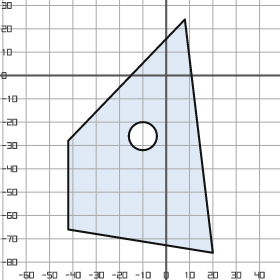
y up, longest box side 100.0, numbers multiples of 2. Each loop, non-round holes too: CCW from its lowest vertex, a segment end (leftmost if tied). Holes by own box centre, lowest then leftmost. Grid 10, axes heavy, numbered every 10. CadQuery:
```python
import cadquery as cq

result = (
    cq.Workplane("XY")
    .moveTo(20.0, -76.0)
    .lineTo(8.0, 24.0)
    .lineTo(-42.0, -28.0)
    .lineTo(-42.0, -66.0)
    .close()
    .moveTo(-10.0, -26.0)
    .circle(6.0)
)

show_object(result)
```